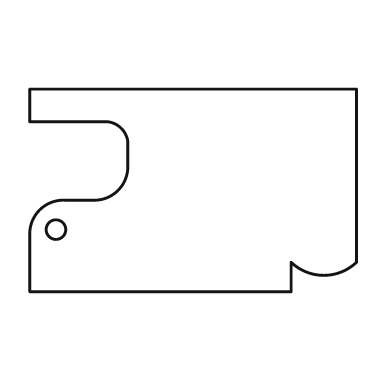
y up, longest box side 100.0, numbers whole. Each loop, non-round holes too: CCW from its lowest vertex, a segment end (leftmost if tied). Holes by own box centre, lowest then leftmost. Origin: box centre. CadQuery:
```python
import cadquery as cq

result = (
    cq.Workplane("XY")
    .moveTo(-50.0, -31.0)
    .lineTo(30.0, -31.0)
    .lineTo(30.0, -22.0)
    .threePointArc((40.0, -26.0), (50.0, -22.0))
    .lineTo(50.0, 31.0)
    .lineTo(-50.0, 31.0)
    .lineTo(-50.0, 21.0)
    .lineTo(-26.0, 21.0)
    .threePointArc((-22.0, 19.0), (-20.0, 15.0))
    .lineTo(-20.0, 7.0)
    .threePointArc((-23.0, 0.0), (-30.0, -3.0))
    .lineTo(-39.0, -3.0)
    .threePointArc((-47.0, -6.0), (-50.0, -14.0))
    .close()
    .moveTo(-42.0, -12.0)
    .circle(3.0)
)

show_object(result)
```